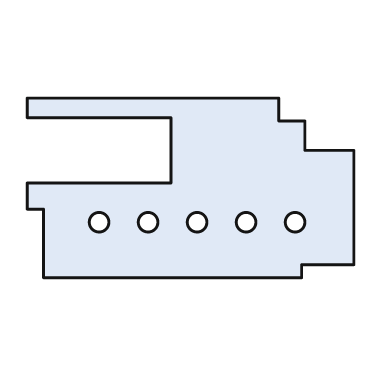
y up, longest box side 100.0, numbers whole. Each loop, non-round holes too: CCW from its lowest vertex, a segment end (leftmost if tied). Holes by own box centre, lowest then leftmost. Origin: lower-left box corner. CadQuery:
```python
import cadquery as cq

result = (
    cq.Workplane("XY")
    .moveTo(5.0, 0.0)
    .lineTo(84.0, 0.0)
    .lineTo(84.0, 4.0)
    .lineTo(100.0, 4.0)
    .lineTo(100.0, 39.0)
    .lineTo(85.0, 39.0)
    .lineTo(85.0, 48.0)
    .lineTo(77.0, 48.0)
    .lineTo(77.0, 55.0)
    .lineTo(0.0, 55.0)
    .lineTo(0.0, 49.0)
    .lineTo(44.0, 49.0)
    .lineTo(44.0, 29.0)
    .lineTo(0.0, 29.0)
    .lineTo(0.0, 21.0)
    .lineTo(5.0, 21.0)
    .close()
    .moveTo(22.0, 17.0)
    .circle(3.0)
    .moveTo(37.0, 17.0)
    .circle(3.0)
    .moveTo(52.0, 17.0)
    .circle(3.0)
    .moveTo(67.0, 17.0)
    .circle(3.0)
    .moveTo(82.0, 17.0)
    .circle(3.0)
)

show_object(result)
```